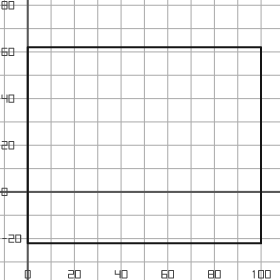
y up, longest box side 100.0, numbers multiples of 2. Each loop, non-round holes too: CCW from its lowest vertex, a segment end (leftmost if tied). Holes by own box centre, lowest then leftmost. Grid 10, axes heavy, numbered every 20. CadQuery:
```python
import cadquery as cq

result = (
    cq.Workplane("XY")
    .moveTo(0.0, -22.0)
    .lineTo(100.0, -22.0)
    .lineTo(100.0, 62.0)
    .lineTo(0.0, 62.0)
    .close()
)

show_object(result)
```